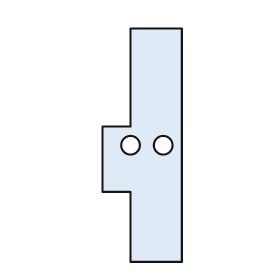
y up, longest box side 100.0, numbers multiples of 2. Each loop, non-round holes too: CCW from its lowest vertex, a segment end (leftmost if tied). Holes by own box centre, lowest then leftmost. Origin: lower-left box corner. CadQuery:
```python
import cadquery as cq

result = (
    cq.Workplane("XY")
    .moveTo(12.0, 0.0)
    .lineTo(34.0, 0.0)
    .lineTo(34.0, 100.0)
    .lineTo(12.0, 100.0)
    .lineTo(12.0, 58.0)
    .lineTo(0.0, 58.0)
    .lineTo(0.0, 30.0)
    .lineTo(12.0, 30.0)
    .close()
    .moveTo(12.0, 50.0)
    .circle(4.0)
    .moveTo(26.0, 50.0)
    .circle(4.0)
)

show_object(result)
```